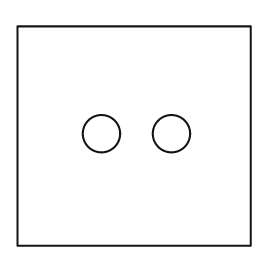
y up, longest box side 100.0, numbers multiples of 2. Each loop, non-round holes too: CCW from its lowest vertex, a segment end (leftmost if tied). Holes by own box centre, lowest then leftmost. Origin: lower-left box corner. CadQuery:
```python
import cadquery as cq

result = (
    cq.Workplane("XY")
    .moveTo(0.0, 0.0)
    .lineTo(100.0, 0.0)
    .lineTo(100.0, 94.0)
    .lineTo(0.0, 94.0)
    .close()
    .moveTo(36.0, 48.0)
    .circle(8.0)
    .moveTo(66.0, 48.0)
    .circle(8.0)
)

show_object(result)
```